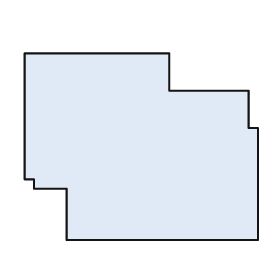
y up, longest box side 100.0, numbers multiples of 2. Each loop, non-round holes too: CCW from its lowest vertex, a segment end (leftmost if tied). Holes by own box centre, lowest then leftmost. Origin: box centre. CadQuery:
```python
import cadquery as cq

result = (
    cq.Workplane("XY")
    .moveTo(-32.0, -40.0)
    .lineTo(50.0, -40.0)
    .lineTo(50.0, 8.0)
    .lineTo(46.0, 8.0)
    .lineTo(46.0, 24.0)
    .lineTo(12.0, 24.0)
    .lineTo(12.0, 40.0)
    .lineTo(-50.0, 40.0)
    .lineTo(-50.0, -14.0)
    .lineTo(-46.0, -14.0)
    .lineTo(-46.0, -18.0)
    .lineTo(-32.0, -18.0)
    .close()
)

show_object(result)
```